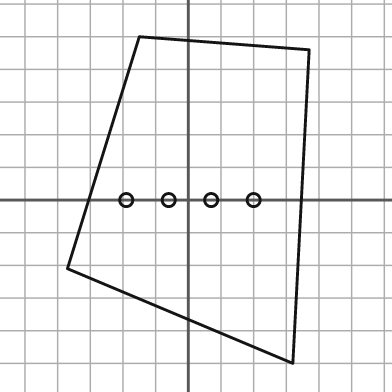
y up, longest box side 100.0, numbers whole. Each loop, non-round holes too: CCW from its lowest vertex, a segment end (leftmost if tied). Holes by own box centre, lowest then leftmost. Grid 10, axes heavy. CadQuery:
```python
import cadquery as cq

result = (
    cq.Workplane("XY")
    .moveTo(32.0, -50.0)
    .lineTo(37.0, 46.0)
    .lineTo(-15.0, 50.0)
    .lineTo(-37.0, -21.0)
    .close()
    .moveTo(-19.0, 0.0)
    .circle(2.0)
    .moveTo(-6.0, 0.0)
    .circle(2.0)
    .moveTo(7.0, 0.0)
    .circle(2.0)
    .moveTo(20.0, 0.0)
    .circle(2.0)
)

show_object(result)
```